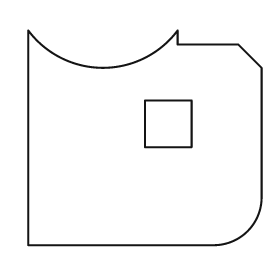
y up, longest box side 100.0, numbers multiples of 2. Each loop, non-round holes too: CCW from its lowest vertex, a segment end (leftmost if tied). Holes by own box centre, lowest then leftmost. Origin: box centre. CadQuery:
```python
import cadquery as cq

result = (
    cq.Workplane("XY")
    .moveTo(-50.0, -46.0)
    .lineTo(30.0, -46.0)
    .threePointArc((44.0, -40.0), (50.0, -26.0))
    .lineTo(50.0, 30.0)
    .lineTo(40.0, 40.0)
    .lineTo(14.0, 40.0)
    .lineTo(14.0, 46.0)
    .threePointArc((-18.0, 30.0), (-50.0, 46.0))
    .close()
    .moveTo(0.0, -4.0)
    .lineTo(20.0, -4.0)
    .lineTo(20.0, 16.0)
    .lineTo(0.0, 16.0)
    .close()
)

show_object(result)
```